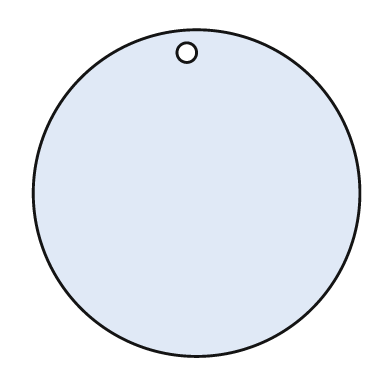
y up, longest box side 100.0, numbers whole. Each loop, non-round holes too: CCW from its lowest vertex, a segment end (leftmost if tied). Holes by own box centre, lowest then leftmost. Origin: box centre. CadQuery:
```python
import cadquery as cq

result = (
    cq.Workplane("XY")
    .moveTo(0.0, 0.0)
    .circle(50.0)
    .moveTo(-3.0, 43.0)
    .circle(3.0)
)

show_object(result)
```